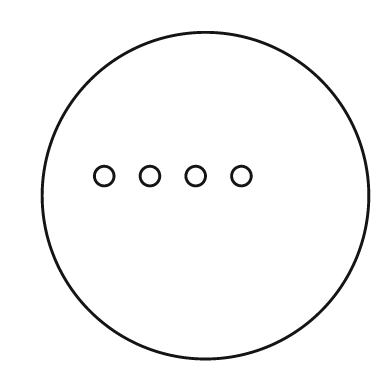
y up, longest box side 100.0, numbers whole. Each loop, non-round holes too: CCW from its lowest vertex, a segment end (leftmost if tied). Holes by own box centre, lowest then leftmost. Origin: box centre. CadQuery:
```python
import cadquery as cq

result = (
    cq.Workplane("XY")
    .moveTo(0.0, 0.0)
    .circle(50.0)
    .moveTo(-31.0, 6.0)
    .circle(3.0)
    .moveTo(-17.0, 6.0)
    .circle(3.0)
    .moveTo(-3.0, 6.0)
    .circle(3.0)
    .moveTo(11.0, 6.0)
    .circle(3.0)
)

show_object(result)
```